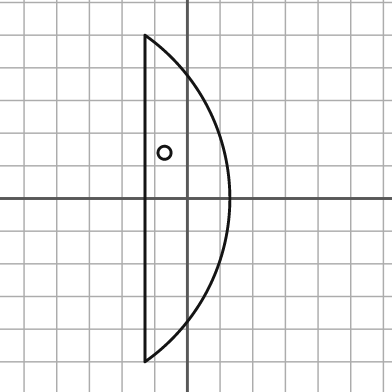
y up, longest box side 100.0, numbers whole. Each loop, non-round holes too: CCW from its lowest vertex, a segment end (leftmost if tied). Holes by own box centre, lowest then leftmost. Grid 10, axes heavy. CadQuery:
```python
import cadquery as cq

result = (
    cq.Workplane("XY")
    .moveTo(-13.0, -50.0)
    .threePointArc((13.0, 0.0), (-13.0, 50.0))
    .close()
    .moveTo(-7.0, 14.0)
    .circle(2.0)
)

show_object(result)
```